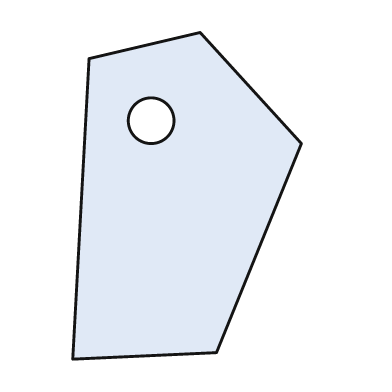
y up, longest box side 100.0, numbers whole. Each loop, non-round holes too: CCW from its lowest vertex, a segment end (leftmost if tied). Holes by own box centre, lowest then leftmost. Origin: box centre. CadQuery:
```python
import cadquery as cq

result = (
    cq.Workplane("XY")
    .moveTo(-35.0, -50.0)
    .lineTo(9.0, -48.0)
    .lineTo(35.0, 16.0)
    .lineTo(4.0, 50.0)
    .lineTo(-30.0, 42.0)
    .close()
    .moveTo(-11.0, 23.0)
    .circle(7.0)
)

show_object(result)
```